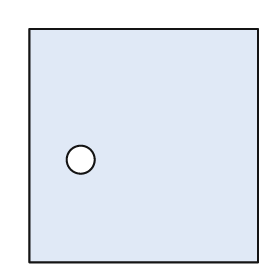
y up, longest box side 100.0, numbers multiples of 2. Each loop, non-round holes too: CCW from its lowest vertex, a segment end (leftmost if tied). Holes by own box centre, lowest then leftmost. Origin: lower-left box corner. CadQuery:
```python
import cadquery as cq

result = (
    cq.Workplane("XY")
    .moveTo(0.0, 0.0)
    .lineTo(98.0, 0.0)
    .lineTo(98.0, 100.0)
    .lineTo(0.0, 100.0)
    .close()
    .moveTo(22.0, 44.0)
    .circle(6.0)
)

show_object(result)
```